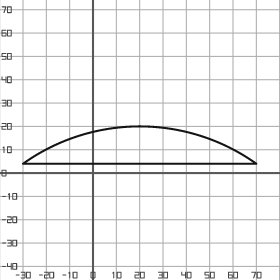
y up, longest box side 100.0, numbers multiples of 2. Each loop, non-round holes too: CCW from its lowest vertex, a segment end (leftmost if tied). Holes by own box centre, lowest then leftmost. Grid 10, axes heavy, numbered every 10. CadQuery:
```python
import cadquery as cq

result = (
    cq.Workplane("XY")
    .moveTo(-30.0, 4.0)
    .lineTo(70.0, 4.0)
    .threePointArc((20.0, 20.0), (-30.0, 4.0))
    .close()
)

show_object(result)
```